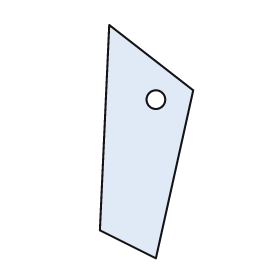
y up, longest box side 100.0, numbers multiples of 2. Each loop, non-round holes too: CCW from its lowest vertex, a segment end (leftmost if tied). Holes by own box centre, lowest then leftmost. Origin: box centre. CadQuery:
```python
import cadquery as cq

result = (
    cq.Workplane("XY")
    .moveTo(4.0, -50.0)
    .lineTo(20.0, 22.0)
    .lineTo(-16.0, 50.0)
    .lineTo(-20.0, -38.0)
    .close()
    .moveTo(4.0, 18.0)
    .circle(4.0)
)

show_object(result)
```